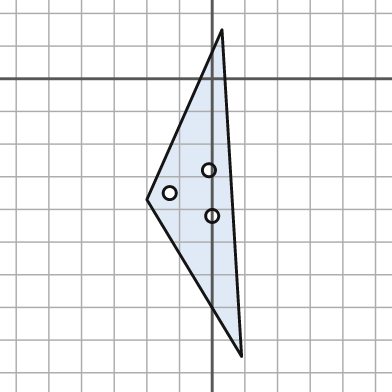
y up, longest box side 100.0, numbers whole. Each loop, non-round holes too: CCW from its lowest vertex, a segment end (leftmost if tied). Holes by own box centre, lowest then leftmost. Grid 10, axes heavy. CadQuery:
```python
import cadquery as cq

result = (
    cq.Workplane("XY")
    .moveTo(9.0, -85.0)
    .lineTo(3.0, 15.0)
    .lineTo(-20.0, -37.0)
    .close()
    .moveTo(0.0, -42.0)
    .circle(2.0)
    .moveTo(-13.0, -35.0)
    .circle(2.0)
    .moveTo(-1.0, -28.0)
    .circle(2.0)
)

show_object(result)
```